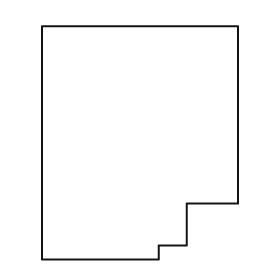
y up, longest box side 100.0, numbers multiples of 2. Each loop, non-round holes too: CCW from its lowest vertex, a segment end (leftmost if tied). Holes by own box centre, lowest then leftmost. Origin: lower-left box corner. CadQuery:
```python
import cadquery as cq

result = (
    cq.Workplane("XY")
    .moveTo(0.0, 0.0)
    .lineTo(50.0, 0.0)
    .lineTo(50.0, 6.0)
    .lineTo(62.0, 6.0)
    .lineTo(62.0, 24.0)
    .lineTo(84.0, 24.0)
    .lineTo(84.0, 100.0)
    .lineTo(0.0, 100.0)
    .close()
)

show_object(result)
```